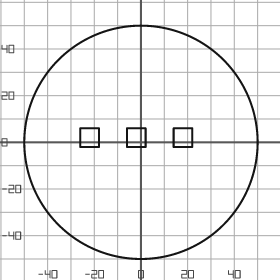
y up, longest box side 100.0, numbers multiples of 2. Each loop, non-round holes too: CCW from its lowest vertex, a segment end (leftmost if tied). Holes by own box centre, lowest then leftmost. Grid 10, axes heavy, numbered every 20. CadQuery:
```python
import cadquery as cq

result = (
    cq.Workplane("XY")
    .moveTo(0.0, 0.0)
    .circle(50.0)
    .moveTo(-26.0, -2.0)
    .lineTo(-18.0, -2.0)
    .lineTo(-18.0, 6.0)
    .lineTo(-26.0, 6.0)
    .close()
    .moveTo(-6.0, -2.0)
    .lineTo(2.0, -2.0)
    .lineTo(2.0, 6.0)
    .lineTo(-6.0, 6.0)
    .close()
    .moveTo(14.0, -2.0)
    .lineTo(22.0, -2.0)
    .lineTo(22.0, 6.0)
    .lineTo(14.0, 6.0)
    .close()
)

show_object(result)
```